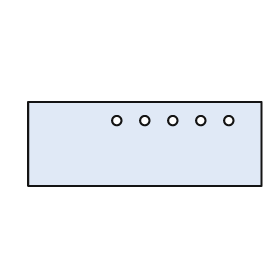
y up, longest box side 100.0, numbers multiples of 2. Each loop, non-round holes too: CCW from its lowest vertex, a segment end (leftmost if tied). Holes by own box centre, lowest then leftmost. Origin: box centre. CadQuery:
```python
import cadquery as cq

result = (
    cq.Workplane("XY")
    .moveTo(-50.0, -18.0)
    .lineTo(50.0, -18.0)
    .lineTo(50.0, 18.0)
    .lineTo(-50.0, 18.0)
    .close()
    .moveTo(-12.0, 10.0)
    .circle(2.0)
    .moveTo(0.0, 10.0)
    .circle(2.0)
    .moveTo(12.0, 10.0)
    .circle(2.0)
    .moveTo(24.0, 10.0)
    .circle(2.0)
    .moveTo(36.0, 10.0)
    .circle(2.0)
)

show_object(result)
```